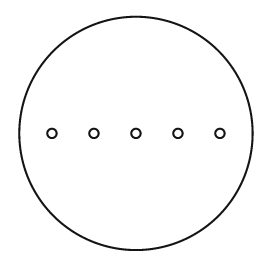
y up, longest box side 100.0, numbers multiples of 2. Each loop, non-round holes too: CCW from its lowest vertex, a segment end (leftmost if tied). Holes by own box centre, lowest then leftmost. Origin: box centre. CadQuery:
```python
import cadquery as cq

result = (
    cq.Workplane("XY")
    .moveTo(0.0, 0.0)
    .circle(50.0)
    .moveTo(-36.0, 0.0)
    .circle(2.0)
    .moveTo(-18.0, 0.0)
    .circle(2.0)
    .moveTo(0.0, 0.0)
    .circle(2.0)
    .moveTo(18.0, 0.0)
    .circle(2.0)
    .moveTo(36.0, 0.0)
    .circle(2.0)
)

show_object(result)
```